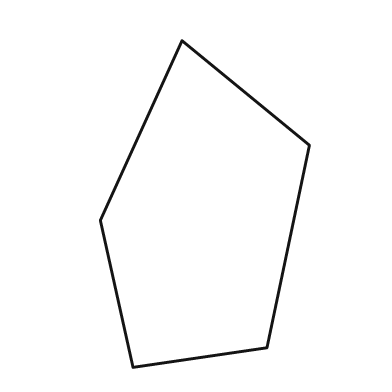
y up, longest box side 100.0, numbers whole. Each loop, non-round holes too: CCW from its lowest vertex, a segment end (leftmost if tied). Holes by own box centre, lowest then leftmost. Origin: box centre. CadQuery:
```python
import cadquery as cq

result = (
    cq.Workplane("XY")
    .moveTo(-22.0, -50.0)
    .lineTo(19.0, -44.0)
    .lineTo(32.0, 18.0)
    .lineTo(-7.0, 50.0)
    .lineTo(-32.0, -5.0)
    .close()
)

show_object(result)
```